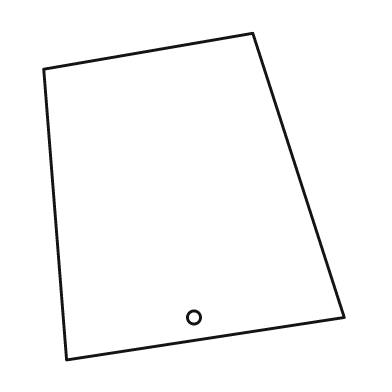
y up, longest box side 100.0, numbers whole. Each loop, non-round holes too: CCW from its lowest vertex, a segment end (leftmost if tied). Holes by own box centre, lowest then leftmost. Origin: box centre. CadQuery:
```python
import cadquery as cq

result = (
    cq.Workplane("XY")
    .moveTo(-39.0, -50.0)
    .lineTo(46.0, -37.0)
    .lineTo(18.0, 50.0)
    .lineTo(-46.0, 39.0)
    .close()
    .moveTo(0.0, -37.0)
    .circle(2.0)
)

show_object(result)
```